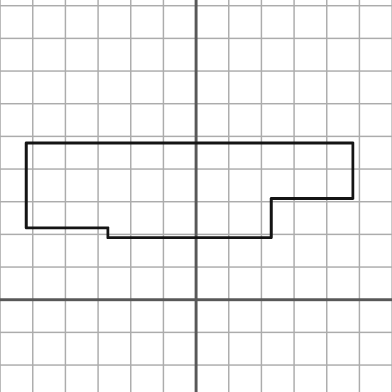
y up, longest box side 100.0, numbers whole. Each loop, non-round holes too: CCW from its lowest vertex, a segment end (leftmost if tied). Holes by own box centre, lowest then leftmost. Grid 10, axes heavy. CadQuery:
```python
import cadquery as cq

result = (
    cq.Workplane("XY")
    .moveTo(-27.0, 19.0)
    .lineTo(23.0, 19.0)
    .lineTo(23.0, 31.0)
    .lineTo(48.0, 31.0)
    .lineTo(48.0, 48.0)
    .lineTo(-52.0, 48.0)
    .lineTo(-52.0, 22.0)
    .lineTo(-27.0, 22.0)
    .close()
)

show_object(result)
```